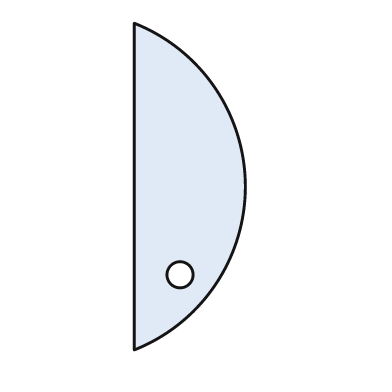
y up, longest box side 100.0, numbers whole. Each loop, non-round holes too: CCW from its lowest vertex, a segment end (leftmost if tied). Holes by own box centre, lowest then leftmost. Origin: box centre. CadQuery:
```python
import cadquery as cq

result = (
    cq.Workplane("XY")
    .moveTo(-17.0, -50.0)
    .threePointArc((17.0, 0.0), (-17.0, 50.0))
    .close()
    .moveTo(-3.0, -27.0)
    .circle(4.0)
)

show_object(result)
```